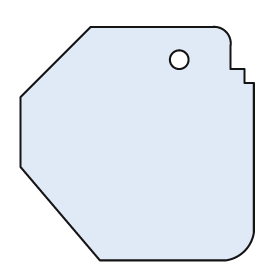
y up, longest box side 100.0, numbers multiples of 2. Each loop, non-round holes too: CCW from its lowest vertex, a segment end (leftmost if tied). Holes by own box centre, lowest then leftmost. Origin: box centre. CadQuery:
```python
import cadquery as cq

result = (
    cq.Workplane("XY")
    .moveTo(-16.0, -50.0)
    .lineTo(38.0, -50.0)
    .threePointArc((46.0, -46.0), (50.0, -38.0))
    .lineTo(50.0, 26.0)
    .lineTo(46.0, 26.0)
    .lineTo(46.0, 32.0)
    .lineTo(40.0, 32.0)
    .lineTo(40.0, 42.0)
    .threePointArc((38.0, 48.0), (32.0, 50.0))
    .lineTo(-20.0, 50.0)
    .lineTo(-50.0, 20.0)
    .lineTo(-50.0, -10.0)
    .close()
    .moveTo(18.0, 36.0)
    .circle(4.0)
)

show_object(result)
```